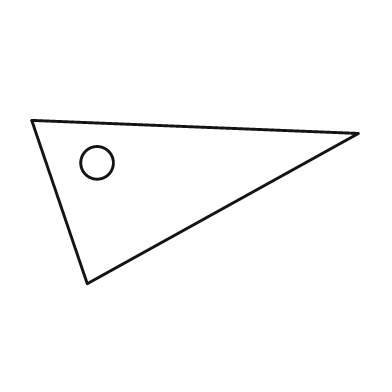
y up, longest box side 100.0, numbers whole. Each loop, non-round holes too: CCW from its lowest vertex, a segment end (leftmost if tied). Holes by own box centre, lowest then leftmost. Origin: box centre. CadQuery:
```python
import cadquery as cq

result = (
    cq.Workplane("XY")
    .moveTo(-33.0, -25.0)
    .lineTo(50.0, 21.0)
    .lineTo(-50.0, 25.0)
    .close()
    .moveTo(-30.0, 12.0)
    .circle(5.0)
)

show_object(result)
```